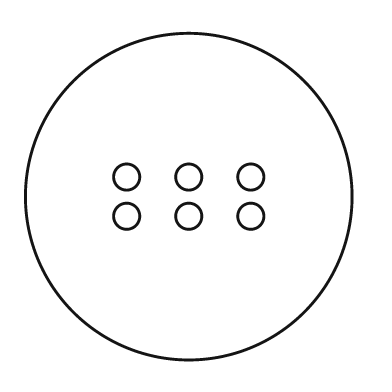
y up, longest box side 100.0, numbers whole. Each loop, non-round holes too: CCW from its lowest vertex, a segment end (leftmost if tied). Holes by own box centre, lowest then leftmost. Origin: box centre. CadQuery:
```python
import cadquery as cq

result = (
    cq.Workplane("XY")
    .moveTo(0.0, 0.0)
    .circle(50.0)
    .moveTo(-19.0, -6.0)
    .circle(4.0)
    .moveTo(0.0, -6.0)
    .circle(4.0)
    .moveTo(19.0, -6.0)
    .circle(4.0)
    .moveTo(-19.0, 6.0)
    .circle(4.0)
    .moveTo(0.0, 6.0)
    .circle(4.0)
    .moveTo(19.0, 6.0)
    .circle(4.0)
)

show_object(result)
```